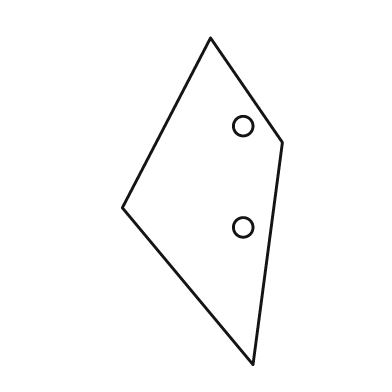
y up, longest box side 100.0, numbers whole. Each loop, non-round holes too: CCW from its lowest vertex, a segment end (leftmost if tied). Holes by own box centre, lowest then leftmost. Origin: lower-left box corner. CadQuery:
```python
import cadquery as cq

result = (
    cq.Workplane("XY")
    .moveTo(40.0, 0.0)
    .lineTo(49.0, 68.0)
    .lineTo(27.0, 100.0)
    .lineTo(0.0, 48.0)
    .close()
    .moveTo(37.0, 42.0)
    .circle(3.0)
    .moveTo(37.0, 73.0)
    .circle(3.0)
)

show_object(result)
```